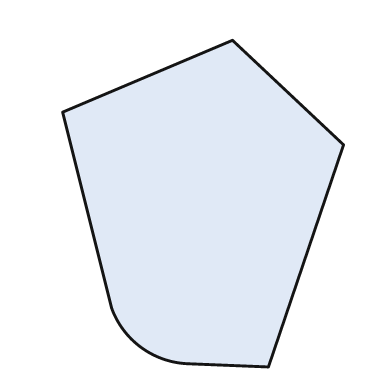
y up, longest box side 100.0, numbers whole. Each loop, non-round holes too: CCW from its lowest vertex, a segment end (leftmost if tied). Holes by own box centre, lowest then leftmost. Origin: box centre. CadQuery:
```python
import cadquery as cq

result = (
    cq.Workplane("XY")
    .moveTo(20.0, -50.0)
    .lineTo(43.0, 18.0)
    .lineTo(9.0, 50.0)
    .lineTo(-43.0, 28.0)
    .lineTo(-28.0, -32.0)
    .threePointArc((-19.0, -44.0), (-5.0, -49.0))
    .close()
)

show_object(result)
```